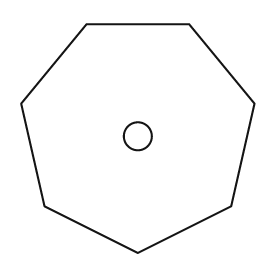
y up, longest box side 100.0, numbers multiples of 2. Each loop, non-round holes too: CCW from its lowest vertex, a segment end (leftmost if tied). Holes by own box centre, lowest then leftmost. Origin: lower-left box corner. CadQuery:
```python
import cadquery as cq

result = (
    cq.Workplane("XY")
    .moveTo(50.0, 0.0)
    .lineTo(90.0, 20.0)
    .lineTo(100.0, 64.0)
    .lineTo(72.0, 98.0)
    .lineTo(28.0, 98.0)
    .lineTo(0.0, 64.0)
    .lineTo(10.0, 20.0)
    .close()
    .moveTo(50.0, 50.0)
    .circle(6.0)
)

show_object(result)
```